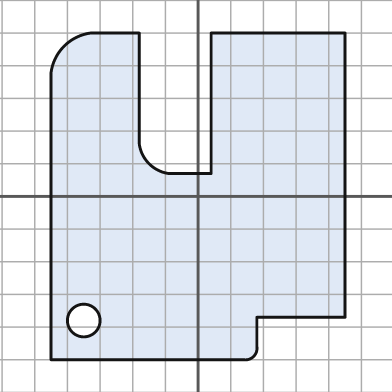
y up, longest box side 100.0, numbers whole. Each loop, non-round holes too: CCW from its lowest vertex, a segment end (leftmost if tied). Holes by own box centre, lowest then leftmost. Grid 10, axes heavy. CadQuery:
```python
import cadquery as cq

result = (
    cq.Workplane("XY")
    .moveTo(-45.0, -50.0)
    .lineTo(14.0, -50.0)
    .threePointArc((17.0, -49.0), (18.0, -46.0))
    .lineTo(18.0, -37.0)
    .lineTo(45.0, -37.0)
    .lineTo(45.0, 50.0)
    .lineTo(4.0, 50.0)
    .lineTo(4.0, 7.0)
    .lineTo(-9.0, 7.0)
    .threePointArc((-15.0, 10.0), (-18.0, 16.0))
    .lineTo(-18.0, 50.0)
    .lineTo(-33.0, 50.0)
    .threePointArc((-41.0, 46.0), (-45.0, 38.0))
    .close()
    .moveTo(-35.0, -38.0)
    .circle(5.0)
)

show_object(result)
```